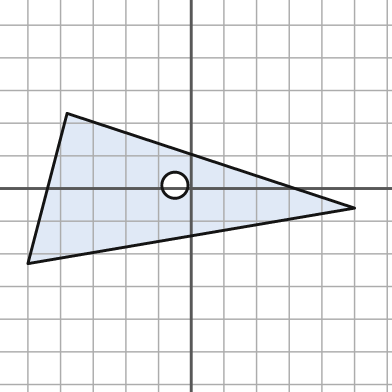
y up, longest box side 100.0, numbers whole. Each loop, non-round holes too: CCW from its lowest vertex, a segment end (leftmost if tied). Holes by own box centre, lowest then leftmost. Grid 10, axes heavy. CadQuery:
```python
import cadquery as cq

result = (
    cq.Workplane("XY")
    .moveTo(-50.0, -23.0)
    .lineTo(50.0, -6.0)
    .lineTo(-38.0, 23.0)
    .close()
    .moveTo(-5.0, 1.0)
    .circle(4.0)
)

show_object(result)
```